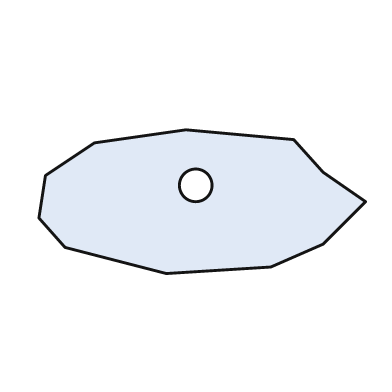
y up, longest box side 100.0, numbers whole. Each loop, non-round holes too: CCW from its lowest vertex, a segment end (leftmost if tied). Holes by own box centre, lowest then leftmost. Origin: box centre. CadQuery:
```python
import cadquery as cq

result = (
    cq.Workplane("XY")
    .moveTo(-11.0, -22.0)
    .lineTo(21.0, -20.0)
    .lineTo(37.0, -13.0)
    .lineTo(50.0, 0.0)
    .lineTo(37.0, 9.0)
    .lineTo(28.0, 19.0)
    .lineTo(-5.0, 22.0)
    .lineTo(-33.0, 18.0)
    .lineTo(-48.0, 8.0)
    .lineTo(-50.0, -5.0)
    .lineTo(-42.0, -14.0)
    .close()
    .moveTo(-2.0, 5.0)
    .circle(5.0)
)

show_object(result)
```